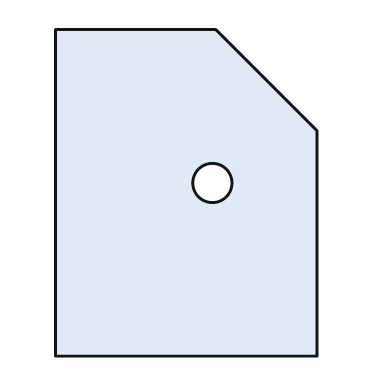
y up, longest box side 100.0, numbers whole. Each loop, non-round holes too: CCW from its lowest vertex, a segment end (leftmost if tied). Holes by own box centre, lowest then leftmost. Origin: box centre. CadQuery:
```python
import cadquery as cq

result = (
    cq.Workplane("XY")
    .moveTo(-40.0, -50.0)
    .lineTo(40.0, -50.0)
    .lineTo(40.0, 19.0)
    .lineTo(9.0, 50.0)
    .lineTo(-40.0, 50.0)
    .close()
    .moveTo(8.0, 3.0)
    .circle(6.0)
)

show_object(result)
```